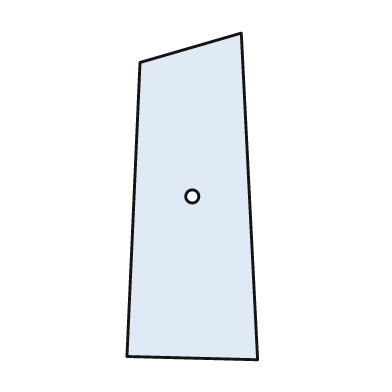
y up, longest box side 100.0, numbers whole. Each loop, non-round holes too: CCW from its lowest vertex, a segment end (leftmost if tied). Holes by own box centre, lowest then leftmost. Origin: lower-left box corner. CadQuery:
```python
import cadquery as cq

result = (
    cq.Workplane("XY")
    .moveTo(40.0, 0.0)
    .lineTo(35.0, 100.0)
    .lineTo(4.0, 91.0)
    .lineTo(0.0, 1.0)
    .close()
    .moveTo(20.0, 50.0)
    .circle(2.0)
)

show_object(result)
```